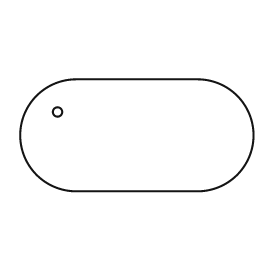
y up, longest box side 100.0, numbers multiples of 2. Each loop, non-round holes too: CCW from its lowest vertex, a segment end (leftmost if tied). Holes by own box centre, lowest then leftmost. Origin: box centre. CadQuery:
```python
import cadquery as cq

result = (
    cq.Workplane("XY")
    .moveTo(-26.0, -24.0)
    .lineTo(26.0, -24.0)
    .threePointArc((50.0, 0.0), (26.0, 24.0))
    .lineTo(-26.0, 24.0)
    .threePointArc((-50.0, 0.0), (-26.0, -24.0))
    .close()
    .moveTo(-34.0, 10.0)
    .circle(2.0)
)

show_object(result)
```